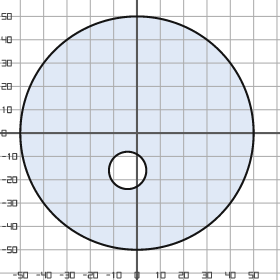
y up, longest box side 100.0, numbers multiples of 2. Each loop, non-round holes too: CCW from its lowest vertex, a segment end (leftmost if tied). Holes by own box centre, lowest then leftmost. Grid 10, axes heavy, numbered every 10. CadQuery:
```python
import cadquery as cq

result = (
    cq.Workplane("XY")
    .moveTo(0.0, 0.0)
    .circle(50.0)
    .moveTo(-4.0, -16.0)
    .circle(8.0)
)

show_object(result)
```